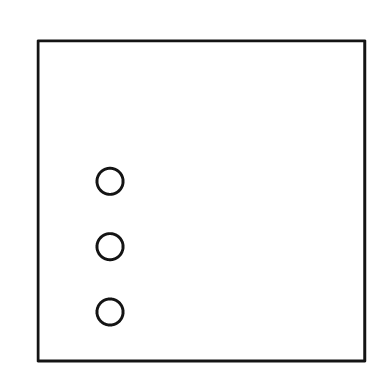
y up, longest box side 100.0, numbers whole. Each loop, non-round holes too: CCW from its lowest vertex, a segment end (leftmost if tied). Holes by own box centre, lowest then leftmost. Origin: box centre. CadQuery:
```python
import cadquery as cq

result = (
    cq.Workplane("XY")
    .moveTo(-50.0, -49.0)
    .lineTo(50.0, -49.0)
    .lineTo(50.0, 49.0)
    .lineTo(-50.0, 49.0)
    .close()
    .moveTo(-28.0, -34.0)
    .circle(4.0)
    .moveTo(-28.0, -14.0)
    .circle(4.0)
    .moveTo(-28.0, 6.0)
    .circle(4.0)
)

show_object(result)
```